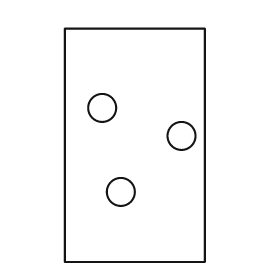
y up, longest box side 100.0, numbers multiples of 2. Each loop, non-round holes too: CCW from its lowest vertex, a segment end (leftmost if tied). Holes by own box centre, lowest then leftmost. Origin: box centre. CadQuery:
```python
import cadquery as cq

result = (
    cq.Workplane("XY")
    .moveTo(-30.0, -50.0)
    .lineTo(30.0, -50.0)
    .lineTo(30.0, 50.0)
    .lineTo(-30.0, 50.0)
    .close()
    .moveTo(-6.0, -20.0)
    .circle(6.0)
    .moveTo(20.0, 4.0)
    .circle(6.0)
    .moveTo(-14.0, 16.0)
    .circle(6.0)
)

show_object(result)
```